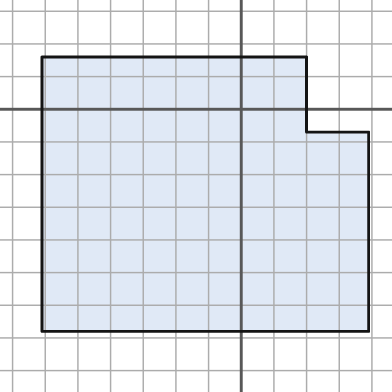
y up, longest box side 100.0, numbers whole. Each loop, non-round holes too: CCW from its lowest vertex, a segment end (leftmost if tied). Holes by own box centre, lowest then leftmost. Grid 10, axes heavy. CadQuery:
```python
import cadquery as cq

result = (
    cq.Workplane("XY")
    .moveTo(-61.0, -68.0)
    .lineTo(39.0, -68.0)
    .lineTo(39.0, -7.0)
    .lineTo(20.0, -7.0)
    .lineTo(20.0, 16.0)
    .lineTo(-61.0, 16.0)
    .close()
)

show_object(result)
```